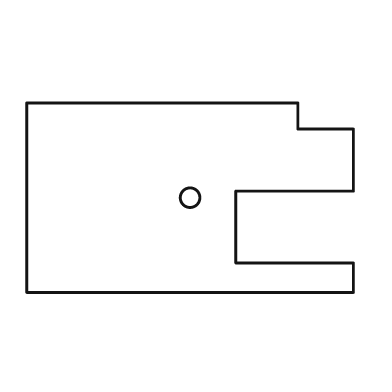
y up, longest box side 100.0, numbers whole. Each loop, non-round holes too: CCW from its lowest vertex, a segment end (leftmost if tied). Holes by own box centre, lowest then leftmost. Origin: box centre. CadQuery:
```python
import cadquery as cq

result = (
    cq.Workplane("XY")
    .moveTo(-50.0, -29.0)
    .lineTo(50.0, -29.0)
    .lineTo(50.0, -20.0)
    .lineTo(14.0, -20.0)
    .lineTo(14.0, 2.0)
    .lineTo(50.0, 2.0)
    .lineTo(50.0, 21.0)
    .lineTo(33.0, 21.0)
    .lineTo(33.0, 29.0)
    .lineTo(-50.0, 29.0)
    .close()
    .moveTo(0.0, 0.0)
    .circle(3.0)
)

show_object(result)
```